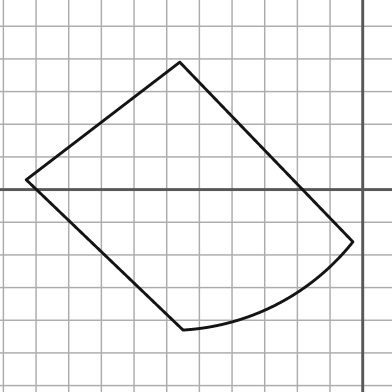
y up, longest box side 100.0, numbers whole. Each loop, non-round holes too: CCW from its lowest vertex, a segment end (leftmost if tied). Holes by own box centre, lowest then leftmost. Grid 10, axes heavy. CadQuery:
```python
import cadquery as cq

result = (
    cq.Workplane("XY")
    .moveTo(-55.0, -43.0)
    .threePointArc((-26.0, -35.0), (-3.0, -16.0))
    .lineTo(-56.0, 39.0)
    .lineTo(-103.0, 3.0)
    .close()
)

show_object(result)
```